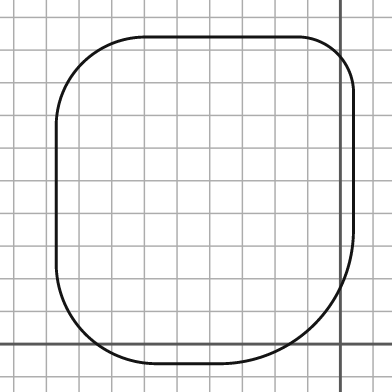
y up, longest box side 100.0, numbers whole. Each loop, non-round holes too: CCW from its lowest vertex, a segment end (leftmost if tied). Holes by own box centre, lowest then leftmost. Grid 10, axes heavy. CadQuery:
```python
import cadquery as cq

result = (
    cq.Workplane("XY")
    .moveTo(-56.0, -6.0)
    .lineTo(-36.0, -6.0)
    .threePointArc((-8.0, 6.0), (4.0, 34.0))
    .lineTo(4.0, 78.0)
    .threePointArc((-1.0, 89.0), (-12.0, 94.0))
    .lineTo(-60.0, 94.0)
    .threePointArc((-79.0, 86.0), (-87.0, 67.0))
    .lineTo(-87.0, 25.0)
    .threePointArc((-78.0, 3.0), (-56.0, -6.0))
    .close()
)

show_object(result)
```